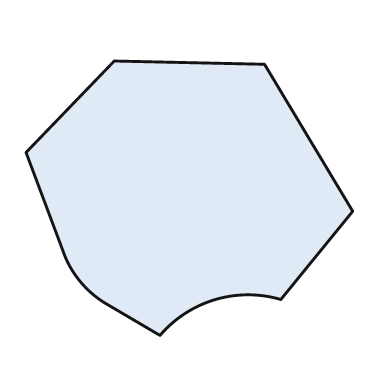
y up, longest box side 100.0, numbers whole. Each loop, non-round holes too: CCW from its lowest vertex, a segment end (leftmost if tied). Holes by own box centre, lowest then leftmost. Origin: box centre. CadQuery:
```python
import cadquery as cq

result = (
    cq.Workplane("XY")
    .moveTo(-9.0, -42.0)
    .threePointArc((8.0, -31.0), (28.0, -31.0))
    .lineTo(50.0, -4.0)
    .lineTo(23.0, 41.0)
    .lineTo(-23.0, 42.0)
    .lineTo(-50.0, 14.0)
    .lineTo(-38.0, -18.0)
    .threePointArc((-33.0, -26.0), (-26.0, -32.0))
    .close()
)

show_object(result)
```